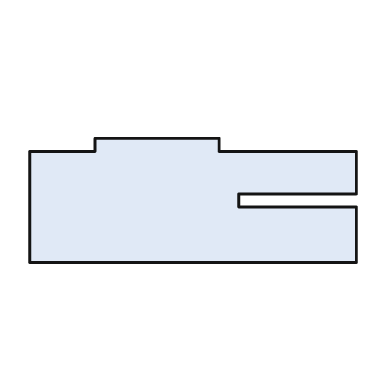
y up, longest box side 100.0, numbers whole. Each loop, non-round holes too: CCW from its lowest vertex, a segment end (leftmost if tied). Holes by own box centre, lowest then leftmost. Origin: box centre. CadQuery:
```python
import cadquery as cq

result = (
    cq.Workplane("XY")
    .moveTo(-50.0, -19.0)
    .lineTo(50.0, -19.0)
    .lineTo(50.0, -2.0)
    .lineTo(14.0, -2.0)
    .lineTo(14.0, 2.0)
    .lineTo(50.0, 2.0)
    .lineTo(50.0, 15.0)
    .lineTo(8.0, 15.0)
    .lineTo(8.0, 19.0)
    .lineTo(-30.0, 19.0)
    .lineTo(-30.0, 15.0)
    .lineTo(-50.0, 15.0)
    .close()
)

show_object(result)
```